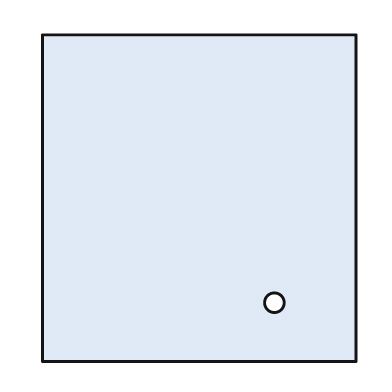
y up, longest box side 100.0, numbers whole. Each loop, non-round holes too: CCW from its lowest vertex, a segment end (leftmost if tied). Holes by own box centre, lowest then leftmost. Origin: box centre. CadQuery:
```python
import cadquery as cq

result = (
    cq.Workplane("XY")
    .moveTo(-48.0, -50.0)
    .lineTo(48.0, -50.0)
    .lineTo(48.0, 50.0)
    .lineTo(-48.0, 50.0)
    .close()
    .moveTo(23.0, -32.0)
    .circle(3.0)
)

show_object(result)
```